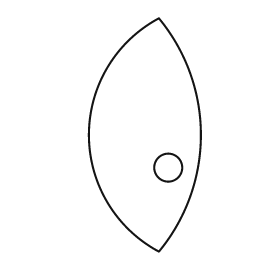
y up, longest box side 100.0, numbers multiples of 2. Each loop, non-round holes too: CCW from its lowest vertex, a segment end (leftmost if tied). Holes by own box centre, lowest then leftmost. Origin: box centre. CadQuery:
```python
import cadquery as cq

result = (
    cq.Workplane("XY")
    .moveTo(6.0, -50.0)
    .threePointArc((24.0, 0.0), (6.0, 50.0))
    .threePointArc((-24.0, 0.0), (6.0, -50.0))
    .close()
    .moveTo(10.0, -14.0)
    .circle(6.0)
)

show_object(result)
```